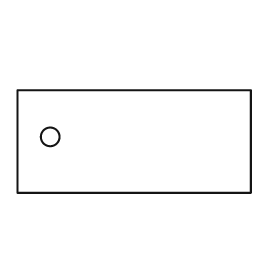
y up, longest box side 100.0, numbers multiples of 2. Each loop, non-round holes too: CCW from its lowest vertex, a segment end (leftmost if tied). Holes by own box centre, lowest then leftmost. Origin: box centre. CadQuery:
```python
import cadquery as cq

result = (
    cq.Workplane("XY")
    .moveTo(-50.0, -22.0)
    .lineTo(50.0, -22.0)
    .lineTo(50.0, 22.0)
    .lineTo(-50.0, 22.0)
    .close()
    .moveTo(-36.0, 2.0)
    .circle(4.0)
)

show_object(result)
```